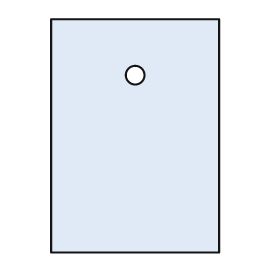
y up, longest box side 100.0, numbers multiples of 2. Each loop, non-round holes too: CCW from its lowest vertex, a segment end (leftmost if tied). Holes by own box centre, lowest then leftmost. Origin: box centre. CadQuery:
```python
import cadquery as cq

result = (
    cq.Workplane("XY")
    .moveTo(-36.0, -50.0)
    .lineTo(36.0, -50.0)
    .lineTo(36.0, 50.0)
    .lineTo(-36.0, 50.0)
    .close()
    .moveTo(0.0, 26.0)
    .circle(4.0)
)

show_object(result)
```